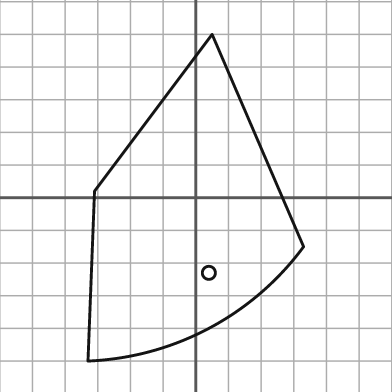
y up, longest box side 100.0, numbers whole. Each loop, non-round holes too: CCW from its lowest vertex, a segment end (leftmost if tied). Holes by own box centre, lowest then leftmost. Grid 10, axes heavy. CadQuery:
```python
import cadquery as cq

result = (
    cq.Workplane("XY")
    .moveTo(-33.0, -50.0)
    .threePointArc((4.0, -40.0), (33.0, -15.0))
    .lineTo(5.0, 50.0)
    .lineTo(-31.0, 2.0)
    .close()
    .moveTo(4.0, -23.0)
    .circle(2.0)
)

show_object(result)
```